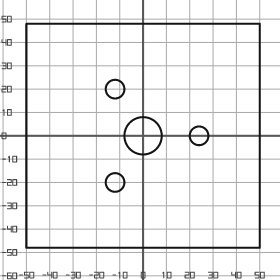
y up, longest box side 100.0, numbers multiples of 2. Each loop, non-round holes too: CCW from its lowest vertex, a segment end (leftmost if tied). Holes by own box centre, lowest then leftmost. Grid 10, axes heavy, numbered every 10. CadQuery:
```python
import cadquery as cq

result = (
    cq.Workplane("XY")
    .moveTo(-50.0, -48.0)
    .lineTo(50.0, -48.0)
    .lineTo(50.0, 48.0)
    .lineTo(-50.0, 48.0)
    .close()
    .moveTo(-12.0, -20.0)
    .circle(4.0)
    .moveTo(0.0, 0.0)
    .circle(8.0)
    .moveTo(24.0, 0.0)
    .circle(4.0)
    .moveTo(-12.0, 20.0)
    .circle(4.0)
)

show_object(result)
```